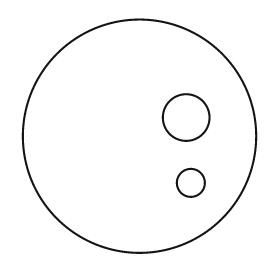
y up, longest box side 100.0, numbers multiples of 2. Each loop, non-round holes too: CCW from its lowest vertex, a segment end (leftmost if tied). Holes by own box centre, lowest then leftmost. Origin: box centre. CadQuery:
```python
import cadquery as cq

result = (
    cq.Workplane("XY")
    .moveTo(0.0, 0.0)
    .circle(50.0)
    .moveTo(22.0, -20.0)
    .circle(6.0)
    .moveTo(20.0, 8.0)
    .circle(10.0)
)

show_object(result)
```